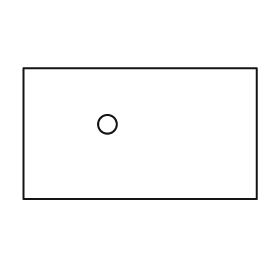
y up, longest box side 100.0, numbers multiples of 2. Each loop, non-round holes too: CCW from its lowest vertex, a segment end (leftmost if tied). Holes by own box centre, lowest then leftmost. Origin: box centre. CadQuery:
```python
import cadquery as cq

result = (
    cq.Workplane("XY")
    .moveTo(-50.0, -28.0)
    .lineTo(50.0, -28.0)
    .lineTo(50.0, 28.0)
    .lineTo(-50.0, 28.0)
    .close()
    .moveTo(-14.0, 4.0)
    .circle(4.0)
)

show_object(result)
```